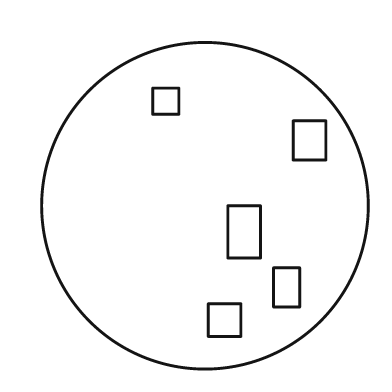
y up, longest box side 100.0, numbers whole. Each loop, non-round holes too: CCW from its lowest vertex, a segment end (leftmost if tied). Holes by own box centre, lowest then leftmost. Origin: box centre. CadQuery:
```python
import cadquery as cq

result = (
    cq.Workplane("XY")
    .moveTo(0.0, 0.0)
    .circle(50.0)
    .moveTo(1.0, -40.0)
    .lineTo(11.0, -40.0)
    .lineTo(11.0, -30.0)
    .lineTo(1.0, -30.0)
    .close()
    .moveTo(21.0, -31.0)
    .lineTo(29.0, -31.0)
    .lineTo(29.0, -19.0)
    .lineTo(21.0, -19.0)
    .close()
    .moveTo(7.0, -16.0)
    .lineTo(17.0, -16.0)
    .lineTo(17.0, 0.0)
    .lineTo(7.0, 0.0)
    .close()
    .moveTo(27.0, 14.0)
    .lineTo(37.0, 14.0)
    .lineTo(37.0, 26.0)
    .lineTo(27.0, 26.0)
    .close()
    .moveTo(-16.0, 28.0)
    .lineTo(-8.0, 28.0)
    .lineTo(-8.0, 36.0)
    .lineTo(-16.0, 36.0)
    .close()
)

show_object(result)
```